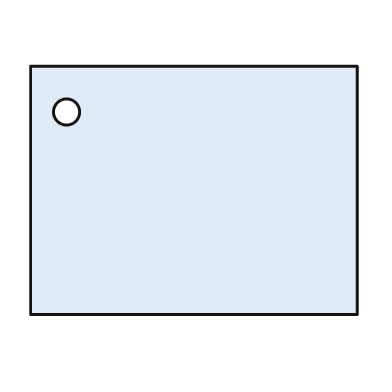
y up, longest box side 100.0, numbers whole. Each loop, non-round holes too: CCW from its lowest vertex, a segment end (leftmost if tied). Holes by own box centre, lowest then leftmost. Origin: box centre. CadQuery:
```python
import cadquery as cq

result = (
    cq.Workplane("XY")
    .moveTo(-50.0, -38.0)
    .lineTo(50.0, -38.0)
    .lineTo(50.0, 38.0)
    .lineTo(-50.0, 38.0)
    .close()
    .moveTo(-39.0, 24.0)
    .circle(4.0)
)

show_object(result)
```